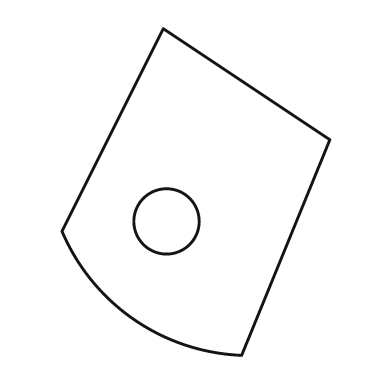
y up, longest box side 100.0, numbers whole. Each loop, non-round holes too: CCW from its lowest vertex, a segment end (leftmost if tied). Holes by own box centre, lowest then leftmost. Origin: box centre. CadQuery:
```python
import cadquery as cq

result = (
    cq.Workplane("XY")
    .moveTo(14.0, -50.0)
    .lineTo(41.0, 16.0)
    .lineTo(-10.0, 50.0)
    .lineTo(-41.0, -12.0)
    .threePointArc((-19.0, -39.0), (14.0, -50.0))
    .close()
    .moveTo(-9.0, -9.0)
    .circle(10.0)
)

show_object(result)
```